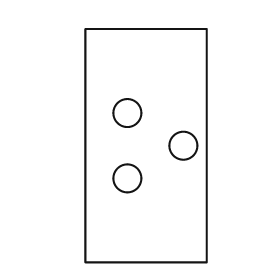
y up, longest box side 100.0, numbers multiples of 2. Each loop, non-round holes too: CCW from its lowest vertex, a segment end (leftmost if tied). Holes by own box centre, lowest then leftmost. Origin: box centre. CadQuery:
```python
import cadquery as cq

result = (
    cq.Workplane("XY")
    .moveTo(-26.0, -50.0)
    .lineTo(26.0, -50.0)
    .lineTo(26.0, 50.0)
    .lineTo(-26.0, 50.0)
    .close()
    .moveTo(-8.0, -14.0)
    .circle(6.0)
    .moveTo(16.0, 0.0)
    .circle(6.0)
    .moveTo(-8.0, 14.0)
    .circle(6.0)
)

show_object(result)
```